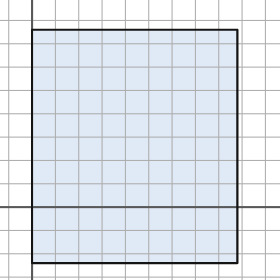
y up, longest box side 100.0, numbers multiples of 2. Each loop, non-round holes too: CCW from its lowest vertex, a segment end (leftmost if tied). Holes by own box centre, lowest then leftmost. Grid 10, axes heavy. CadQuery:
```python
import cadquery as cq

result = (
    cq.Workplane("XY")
    .moveTo(0.0, -24.0)
    .lineTo(88.0, -24.0)
    .lineTo(88.0, 76.0)
    .lineTo(0.0, 76.0)
    .close()
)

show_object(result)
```